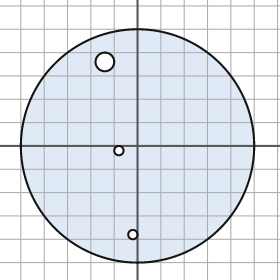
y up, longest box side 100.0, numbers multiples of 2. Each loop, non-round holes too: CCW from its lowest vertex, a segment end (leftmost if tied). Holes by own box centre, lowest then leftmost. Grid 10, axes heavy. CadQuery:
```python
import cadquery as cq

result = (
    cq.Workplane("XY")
    .moveTo(0.0, 0.0)
    .circle(50.0)
    .moveTo(-2.0, -38.0)
    .circle(2.0)
    .moveTo(-8.0, -2.0)
    .circle(2.0)
    .moveTo(-14.0, 36.0)
    .circle(4.0)
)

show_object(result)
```